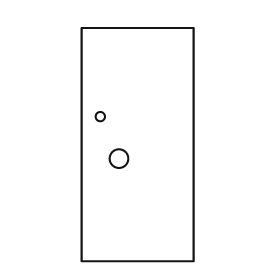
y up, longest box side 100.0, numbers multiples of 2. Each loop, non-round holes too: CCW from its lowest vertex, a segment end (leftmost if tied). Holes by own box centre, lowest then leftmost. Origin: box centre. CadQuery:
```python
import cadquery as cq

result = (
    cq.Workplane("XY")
    .moveTo(-24.0, -50.0)
    .lineTo(24.0, -50.0)
    .lineTo(24.0, 50.0)
    .lineTo(-24.0, 50.0)
    .close()
    .moveTo(-8.0, -6.0)
    .circle(4.0)
    .moveTo(-16.0, 12.0)
    .circle(2.0)
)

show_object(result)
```